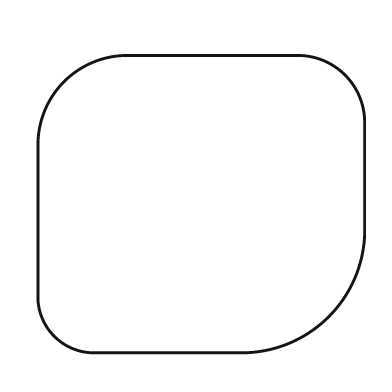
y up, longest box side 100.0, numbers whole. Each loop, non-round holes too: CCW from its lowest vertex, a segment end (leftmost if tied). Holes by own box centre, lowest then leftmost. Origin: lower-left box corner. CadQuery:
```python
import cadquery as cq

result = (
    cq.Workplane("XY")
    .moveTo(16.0, 0.0)
    .lineTo(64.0, 0.0)
    .threePointArc((89.0, 11.0), (100.0, 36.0))
    .lineTo(100.0, 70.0)
    .threePointArc((94.0, 85.0), (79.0, 91.0))
    .lineTo(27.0, 91.0)
    .threePointArc((8.0, 83.0), (0.0, 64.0))
    .lineTo(0.0, 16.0)
    .threePointArc((5.0, 5.0), (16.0, 0.0))
    .close()
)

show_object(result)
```